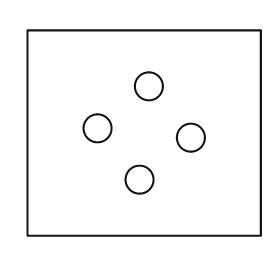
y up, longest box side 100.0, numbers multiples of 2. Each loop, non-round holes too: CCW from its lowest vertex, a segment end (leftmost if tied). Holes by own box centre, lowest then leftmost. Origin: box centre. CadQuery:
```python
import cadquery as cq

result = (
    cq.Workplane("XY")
    .moveTo(-50.0, -44.0)
    .lineTo(50.0, -44.0)
    .lineTo(50.0, 44.0)
    .lineTo(-50.0, 44.0)
    .close()
    .moveTo(-2.0, -20.0)
    .circle(6.0)
    .moveTo(20.0, -2.0)
    .circle(6.0)
    .moveTo(-20.0, 2.0)
    .circle(6.0)
    .moveTo(2.0, 20.0)
    .circle(6.0)
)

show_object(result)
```